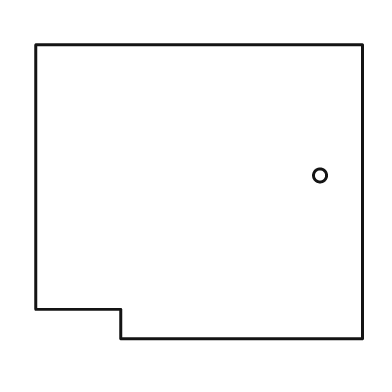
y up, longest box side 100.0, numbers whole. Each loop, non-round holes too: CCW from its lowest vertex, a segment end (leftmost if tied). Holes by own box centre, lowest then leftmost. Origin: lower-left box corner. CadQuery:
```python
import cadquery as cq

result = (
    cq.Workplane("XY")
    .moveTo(26.0, 0.0)
    .lineTo(100.0, 0.0)
    .lineTo(100.0, 90.0)
    .lineTo(0.0, 90.0)
    .lineTo(0.0, 9.0)
    .lineTo(26.0, 9.0)
    .close()
    .moveTo(87.0, 50.0)
    .circle(2.0)
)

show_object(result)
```